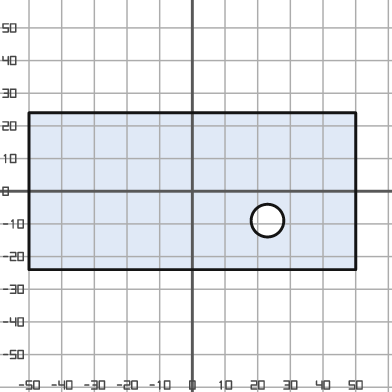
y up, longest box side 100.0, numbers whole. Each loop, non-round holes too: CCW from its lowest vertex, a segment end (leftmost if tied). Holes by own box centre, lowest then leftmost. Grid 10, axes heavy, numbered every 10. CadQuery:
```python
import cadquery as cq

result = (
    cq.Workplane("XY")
    .moveTo(-50.0, -24.0)
    .lineTo(50.0, -24.0)
    .lineTo(50.0, 24.0)
    .lineTo(-50.0, 24.0)
    .close()
    .moveTo(23.0, -9.0)
    .circle(5.0)
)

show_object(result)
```